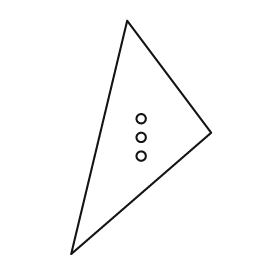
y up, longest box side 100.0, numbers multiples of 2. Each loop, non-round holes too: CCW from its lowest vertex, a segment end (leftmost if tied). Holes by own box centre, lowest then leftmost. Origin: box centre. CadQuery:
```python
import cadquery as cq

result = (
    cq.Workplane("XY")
    .moveTo(-30.0, -50.0)
    .lineTo(30.0, 2.0)
    .lineTo(-6.0, 50.0)
    .close()
    .moveTo(0.0, -8.0)
    .circle(2.0)
    .moveTo(0.0, 0.0)
    .circle(2.0)
    .moveTo(0.0, 8.0)
    .circle(2.0)
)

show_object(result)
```